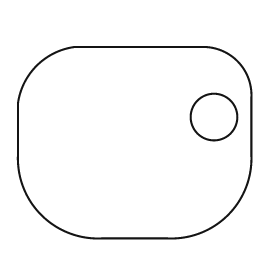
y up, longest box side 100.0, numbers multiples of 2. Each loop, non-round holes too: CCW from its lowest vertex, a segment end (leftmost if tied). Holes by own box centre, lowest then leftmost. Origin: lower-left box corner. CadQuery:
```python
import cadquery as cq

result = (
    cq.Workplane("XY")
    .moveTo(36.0, 0.0)
    .lineTo(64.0, 0.0)
    .threePointArc((90.0, 10.0), (100.0, 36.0))
    .lineTo(100.0, 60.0)
    .threePointArc((94.0, 76.0), (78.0, 82.0))
    .lineTo(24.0, 82.0)
    .threePointArc((8.0, 74.0), (0.0, 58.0))
    .lineTo(0.0, 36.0)
    .threePointArc((10.0, 10.0), (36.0, 0.0))
    .close()
    .moveTo(84.0, 52.0)
    .circle(10.0)
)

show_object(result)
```